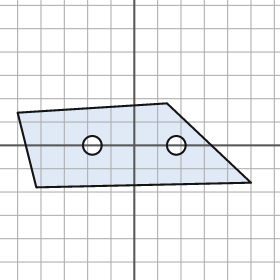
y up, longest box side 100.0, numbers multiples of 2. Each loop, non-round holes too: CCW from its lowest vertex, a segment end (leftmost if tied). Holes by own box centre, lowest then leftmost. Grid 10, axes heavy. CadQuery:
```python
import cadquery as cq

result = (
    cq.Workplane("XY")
    .moveTo(-42.0, -18.0)
    .lineTo(50.0, -16.0)
    .lineTo(14.0, 18.0)
    .lineTo(-50.0, 14.0)
    .close()
    .moveTo(-18.0, 0.0)
    .circle(4.0)
    .moveTo(18.0, 0.0)
    .circle(4.0)
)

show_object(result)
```